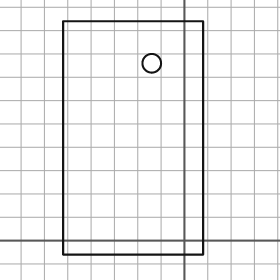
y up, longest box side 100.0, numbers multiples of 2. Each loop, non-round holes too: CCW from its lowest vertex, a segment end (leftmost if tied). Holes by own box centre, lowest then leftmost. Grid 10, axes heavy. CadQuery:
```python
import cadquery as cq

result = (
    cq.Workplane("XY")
    .moveTo(-52.0, -6.0)
    .lineTo(8.0, -6.0)
    .lineTo(8.0, 94.0)
    .lineTo(-52.0, 94.0)
    .close()
    .moveTo(-14.0, 76.0)
    .circle(4.0)
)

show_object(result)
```